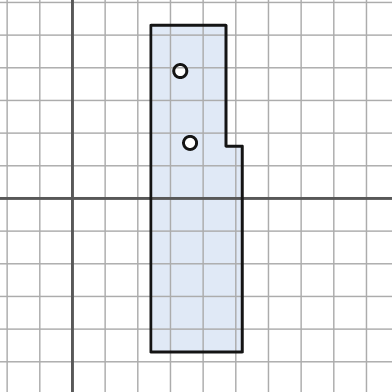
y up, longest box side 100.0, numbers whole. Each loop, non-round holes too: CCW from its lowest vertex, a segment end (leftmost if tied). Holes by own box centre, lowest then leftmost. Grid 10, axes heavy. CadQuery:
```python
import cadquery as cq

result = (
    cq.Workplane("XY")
    .moveTo(24.0, -47.0)
    .lineTo(52.0, -47.0)
    .lineTo(52.0, 16.0)
    .lineTo(47.0, 16.0)
    .lineTo(47.0, 53.0)
    .lineTo(24.0, 53.0)
    .close()
    .moveTo(36.0, 17.0)
    .circle(2.0)
    .moveTo(33.0, 39.0)
    .circle(2.0)
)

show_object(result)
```